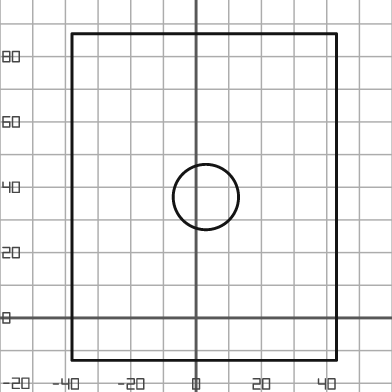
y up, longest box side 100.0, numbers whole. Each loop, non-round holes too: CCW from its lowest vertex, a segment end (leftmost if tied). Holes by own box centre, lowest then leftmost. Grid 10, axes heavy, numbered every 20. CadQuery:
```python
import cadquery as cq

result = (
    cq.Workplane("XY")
    .moveTo(-38.0, -13.0)
    .lineTo(43.0, -13.0)
    .lineTo(43.0, 87.0)
    .lineTo(-38.0, 87.0)
    .close()
    .moveTo(3.0, 37.0)
    .circle(10.0)
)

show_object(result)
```